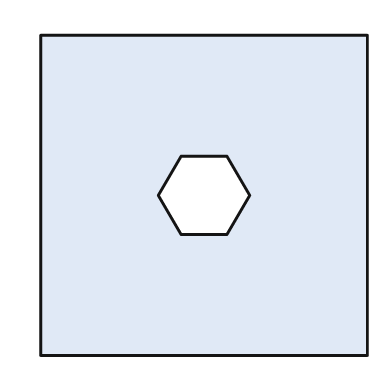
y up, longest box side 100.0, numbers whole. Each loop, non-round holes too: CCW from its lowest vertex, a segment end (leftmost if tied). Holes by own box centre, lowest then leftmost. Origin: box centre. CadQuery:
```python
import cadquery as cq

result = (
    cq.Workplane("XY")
    .moveTo(-50.0, -49.0)
    .lineTo(50.0, -49.0)
    .lineTo(50.0, 49.0)
    .lineTo(-50.0, 49.0)
    .close()
    .moveTo(-7.0, -12.0)
    .lineTo(7.0, -12.0)
    .lineTo(14.0, 0.0)
    .lineTo(7.0, 12.0)
    .lineTo(-7.0, 12.0)
    .lineTo(-14.0, 0.0)
    .close()
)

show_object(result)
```